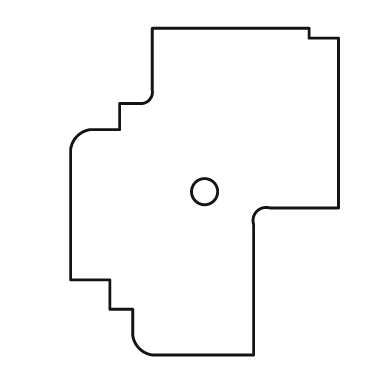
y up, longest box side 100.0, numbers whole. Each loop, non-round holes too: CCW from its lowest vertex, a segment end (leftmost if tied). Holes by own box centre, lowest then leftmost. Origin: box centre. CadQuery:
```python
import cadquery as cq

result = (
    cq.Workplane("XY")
    .moveTo(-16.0, -50.0)
    .lineTo(15.0, -50.0)
    .lineTo(15.0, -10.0)
    .threePointArc((16.0, -6.0), (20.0, -5.0))
    .lineTo(41.0, -5.0)
    .lineTo(41.0, 47.0)
    .lineTo(32.0, 47.0)
    .lineTo(32.0, 50.0)
    .lineTo(-16.0, 50.0)
    .lineTo(-16.0, 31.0)
    .threePointArc((-17.0, 28.0), (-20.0, 27.0))
    .lineTo(-26.0, 27.0)
    .lineTo(-26.0, 19.0)
    .lineTo(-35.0, 19.0)
    .threePointArc((-39.0, 17.0), (-41.0, 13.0))
    .lineTo(-41.0, -27.0)
    .lineTo(-29.0, -27.0)
    .lineTo(-29.0, -36.0)
    .lineTo(-22.0, -36.0)
    .lineTo(-22.0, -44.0)
    .threePointArc((-20.0, -48.0), (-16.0, -50.0))
    .close()
    .moveTo(0.0, 0.0)
    .circle(4.0)
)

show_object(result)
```